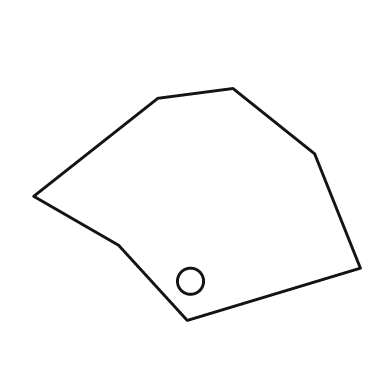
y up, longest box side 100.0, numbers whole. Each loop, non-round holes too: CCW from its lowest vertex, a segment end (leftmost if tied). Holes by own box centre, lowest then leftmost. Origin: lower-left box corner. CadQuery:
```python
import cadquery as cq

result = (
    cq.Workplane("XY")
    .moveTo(47.0, 0.0)
    .lineTo(100.0, 16.0)
    .lineTo(86.0, 51.0)
    .lineTo(61.0, 71.0)
    .lineTo(38.0, 68.0)
    .lineTo(0.0, 38.0)
    .lineTo(26.0, 23.0)
    .close()
    .moveTo(48.0, 12.0)
    .circle(4.0)
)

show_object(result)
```